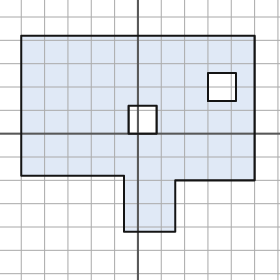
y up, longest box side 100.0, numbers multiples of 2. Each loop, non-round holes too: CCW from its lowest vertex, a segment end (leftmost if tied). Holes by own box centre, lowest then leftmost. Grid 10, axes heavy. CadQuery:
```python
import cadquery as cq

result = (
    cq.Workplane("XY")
    .moveTo(-6.0, -42.0)
    .lineTo(16.0, -42.0)
    .lineTo(16.0, -20.0)
    .lineTo(50.0, -20.0)
    .lineTo(50.0, 42.0)
    .lineTo(-50.0, 42.0)
    .lineTo(-50.0, -18.0)
    .lineTo(-6.0, -18.0)
    .close()
    .moveTo(-4.0, 0.0)
    .lineTo(8.0, 0.0)
    .lineTo(8.0, 12.0)
    .lineTo(-4.0, 12.0)
    .close()
    .moveTo(30.0, 14.0)
    .lineTo(42.0, 14.0)
    .lineTo(42.0, 26.0)
    .lineTo(30.0, 26.0)
    .close()
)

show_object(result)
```